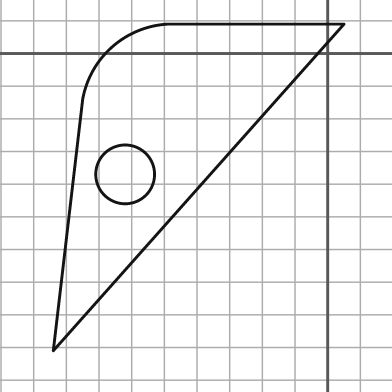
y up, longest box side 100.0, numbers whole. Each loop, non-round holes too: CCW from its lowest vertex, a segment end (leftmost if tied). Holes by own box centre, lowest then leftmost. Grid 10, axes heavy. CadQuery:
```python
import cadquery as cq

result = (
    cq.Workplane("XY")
    .moveTo(-84.0, -91.0)
    .lineTo(5.0, 9.0)
    .lineTo(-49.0, 9.0)
    .threePointArc((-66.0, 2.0), (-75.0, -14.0))
    .close()
    .moveTo(-62.0, -37.0)
    .circle(9.0)
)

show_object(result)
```